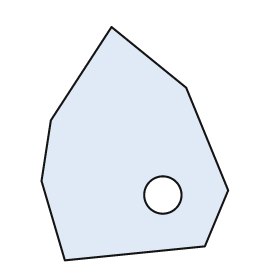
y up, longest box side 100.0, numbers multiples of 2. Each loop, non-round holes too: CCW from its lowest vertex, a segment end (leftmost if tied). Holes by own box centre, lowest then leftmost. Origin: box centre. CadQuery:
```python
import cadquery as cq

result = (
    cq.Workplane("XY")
    .moveTo(-30.0, -50.0)
    .lineTo(30.0, -44.0)
    .lineTo(40.0, -20.0)
    .lineTo(22.0, 24.0)
    .lineTo(-10.0, 50.0)
    .lineTo(-36.0, 10.0)
    .lineTo(-40.0, -16.0)
    .close()
    .moveTo(12.0, -22.0)
    .circle(8.0)
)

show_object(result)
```